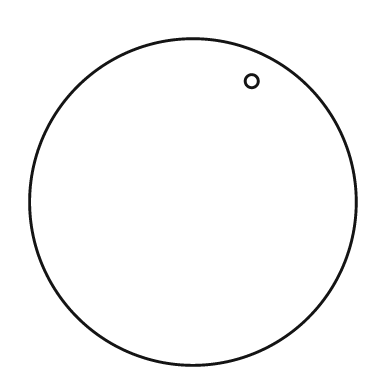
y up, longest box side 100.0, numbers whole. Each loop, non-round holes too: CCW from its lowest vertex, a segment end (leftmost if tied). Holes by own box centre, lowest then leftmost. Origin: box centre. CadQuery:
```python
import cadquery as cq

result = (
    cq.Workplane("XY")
    .moveTo(0.0, 0.0)
    .circle(50.0)
    .moveTo(18.0, 37.0)
    .circle(2.0)
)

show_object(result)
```